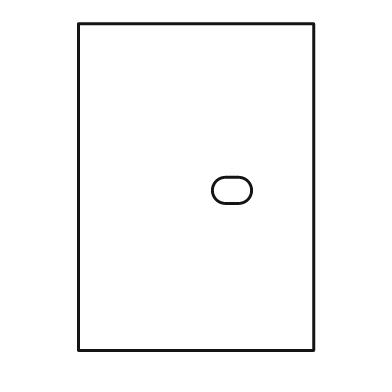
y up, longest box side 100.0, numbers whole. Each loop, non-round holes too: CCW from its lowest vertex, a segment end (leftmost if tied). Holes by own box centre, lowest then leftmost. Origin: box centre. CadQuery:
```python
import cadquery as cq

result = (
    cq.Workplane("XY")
    .moveTo(-36.0, -50.0)
    .lineTo(36.0, -50.0)
    .lineTo(36.0, 50.0)
    .lineTo(-36.0, 50.0)
    .close()
    .moveTo(9.0, -5.0)
    .lineTo(13.0, -5.0)
    .threePointArc((17.0, -1.0), (13.0, 3.0))
    .lineTo(9.0, 3.0)
    .threePointArc((5.0, -1.0), (9.0, -5.0))
    .close()
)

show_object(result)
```